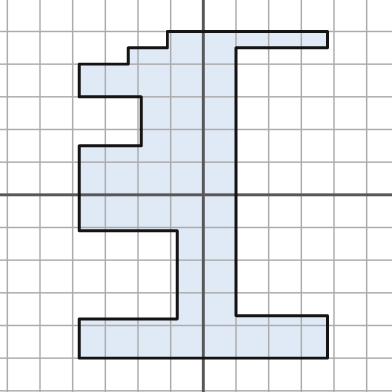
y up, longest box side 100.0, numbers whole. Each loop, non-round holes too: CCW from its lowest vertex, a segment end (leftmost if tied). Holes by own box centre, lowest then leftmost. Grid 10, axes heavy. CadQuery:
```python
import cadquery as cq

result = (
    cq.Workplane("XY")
    .moveTo(-38.0, -50.0)
    .lineTo(38.0, -50.0)
    .lineTo(38.0, -37.0)
    .lineTo(10.0, -37.0)
    .lineTo(10.0, 45.0)
    .lineTo(38.0, 45.0)
    .lineTo(38.0, 50.0)
    .lineTo(-11.0, 50.0)
    .lineTo(-11.0, 45.0)
    .lineTo(-23.0, 45.0)
    .lineTo(-23.0, 40.0)
    .lineTo(-38.0, 40.0)
    .lineTo(-38.0, 30.0)
    .lineTo(-19.0, 30.0)
    .lineTo(-19.0, 15.0)
    .lineTo(-38.0, 15.0)
    .lineTo(-38.0, -11.0)
    .lineTo(-8.0, -11.0)
    .lineTo(-8.0, -38.0)
    .lineTo(-38.0, -38.0)
    .close()
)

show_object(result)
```